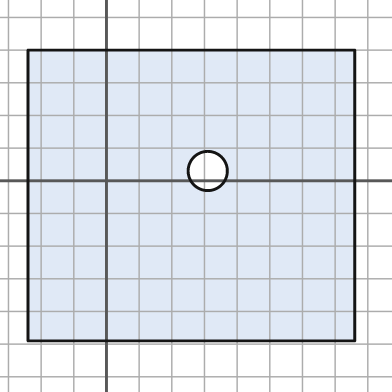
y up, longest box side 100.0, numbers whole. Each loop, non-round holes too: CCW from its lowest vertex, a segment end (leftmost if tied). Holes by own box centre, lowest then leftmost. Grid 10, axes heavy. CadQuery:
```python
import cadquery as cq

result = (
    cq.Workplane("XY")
    .moveTo(-24.0, -49.0)
    .lineTo(76.0, -49.0)
    .lineTo(76.0, 40.0)
    .lineTo(-24.0, 40.0)
    .close()
    .moveTo(31.0, 3.0)
    .circle(6.0)
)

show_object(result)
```